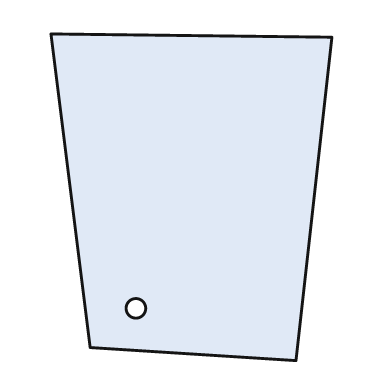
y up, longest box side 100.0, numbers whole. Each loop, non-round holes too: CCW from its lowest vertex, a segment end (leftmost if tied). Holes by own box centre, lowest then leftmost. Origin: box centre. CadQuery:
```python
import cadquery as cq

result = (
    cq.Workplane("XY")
    .moveTo(32.0, -50.0)
    .lineTo(43.0, 49.0)
    .lineTo(-43.0, 50.0)
    .lineTo(-31.0, -46.0)
    .close()
    .moveTo(-17.0, -34.0)
    .circle(3.0)
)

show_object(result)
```